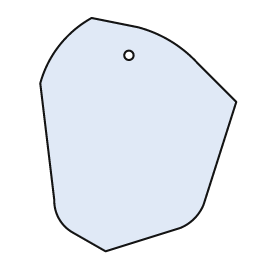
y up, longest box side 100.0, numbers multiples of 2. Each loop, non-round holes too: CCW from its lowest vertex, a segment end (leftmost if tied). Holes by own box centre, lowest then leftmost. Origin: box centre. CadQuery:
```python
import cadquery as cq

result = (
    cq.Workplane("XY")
    .moveTo(-14.0, -50.0)
    .lineTo(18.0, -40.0)
    .threePointArc((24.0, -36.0), (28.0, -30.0))
    .lineTo(42.0, 14.0)
    .lineTo(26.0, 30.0)
    .threePointArc((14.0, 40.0), (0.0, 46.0))
    .lineTo(-20.0, 50.0)
    .threePointArc((-34.0, 38.0), (-42.0, 22.0))
    .lineTo(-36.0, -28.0)
    .threePointArc((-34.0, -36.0), (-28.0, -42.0))
    .close()
    .moveTo(-4.0, 34.0)
    .circle(2.0)
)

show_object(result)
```